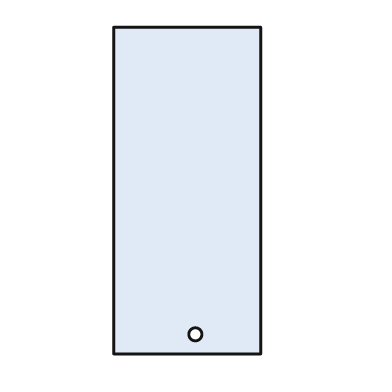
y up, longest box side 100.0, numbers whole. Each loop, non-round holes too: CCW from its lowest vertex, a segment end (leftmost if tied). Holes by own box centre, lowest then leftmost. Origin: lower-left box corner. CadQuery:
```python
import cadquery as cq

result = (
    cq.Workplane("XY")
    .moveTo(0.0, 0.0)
    .lineTo(45.0, 0.0)
    .lineTo(45.0, 100.0)
    .lineTo(0.0, 100.0)
    .close()
    .moveTo(25.0, 6.0)
    .circle(2.0)
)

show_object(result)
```